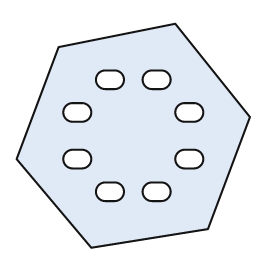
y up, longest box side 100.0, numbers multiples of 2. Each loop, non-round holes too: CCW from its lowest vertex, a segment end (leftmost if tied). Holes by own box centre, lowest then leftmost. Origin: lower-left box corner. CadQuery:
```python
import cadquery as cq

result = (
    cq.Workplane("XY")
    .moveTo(32.0, 0.0)
    .lineTo(82.0, 8.0)
    .lineTo(100.0, 56.0)
    .lineTo(68.0, 96.0)
    .lineTo(18.0, 86.0)
    .lineTo(0.0, 38.0)
    .close()
    .moveTo(38.0, 20.0)
    .lineTo(42.0, 20.0)
    .threePointArc((46.0, 24.0), (42.0, 28.0))
    .lineTo(38.0, 28.0)
    .threePointArc((34.0, 24.0), (38.0, 20.0))
    .close()
    .moveTo(58.0, 20.0)
    .lineTo(62.0, 20.0)
    .threePointArc((66.0, 24.0), (62.0, 28.0))
    .lineTo(58.0, 28.0)
    .threePointArc((54.0, 24.0), (58.0, 20.0))
    .close()
    .moveTo(24.0, 34.0)
    .lineTo(28.0, 34.0)
    .threePointArc((32.0, 38.0), (28.0, 42.0))
    .lineTo(24.0, 42.0)
    .threePointArc((20.0, 38.0), (24.0, 34.0))
    .close()
    .moveTo(72.0, 34.0)
    .lineTo(76.0, 34.0)
    .threePointArc((80.0, 38.0), (76.0, 42.0))
    .lineTo(72.0, 42.0)
    .threePointArc((68.0, 38.0), (72.0, 34.0))
    .close()
    .moveTo(24.0, 54.0)
    .lineTo(28.0, 54.0)
    .threePointArc((32.0, 58.0), (28.0, 62.0))
    .lineTo(24.0, 62.0)
    .threePointArc((20.0, 58.0), (24.0, 54.0))
    .close()
    .moveTo(72.0, 54.0)
    .lineTo(76.0, 54.0)
    .threePointArc((80.0, 58.0), (76.0, 62.0))
    .lineTo(72.0, 62.0)
    .threePointArc((68.0, 58.0), (72.0, 54.0))
    .close()
    .moveTo(38.0, 68.0)
    .lineTo(42.0, 68.0)
    .threePointArc((46.0, 72.0), (42.0, 76.0))
    .lineTo(38.0, 76.0)
    .threePointArc((34.0, 72.0), (38.0, 68.0))
    .close()
    .moveTo(58.0, 68.0)
    .lineTo(62.0, 68.0)
    .threePointArc((66.0, 72.0), (62.0, 76.0))
    .lineTo(58.0, 76.0)
    .threePointArc((54.0, 72.0), (58.0, 68.0))
    .close()
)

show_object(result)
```